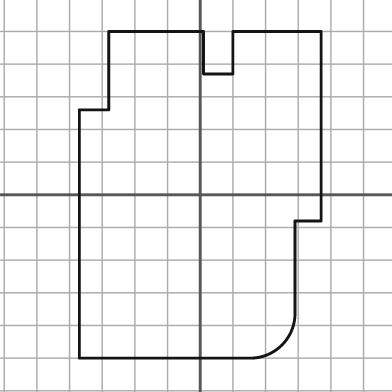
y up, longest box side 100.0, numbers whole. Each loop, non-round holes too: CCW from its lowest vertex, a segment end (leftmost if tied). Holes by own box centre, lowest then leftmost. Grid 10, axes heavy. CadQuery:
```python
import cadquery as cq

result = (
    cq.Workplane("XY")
    .moveTo(-37.0, -50.0)
    .lineTo(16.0, -50.0)
    .threePointArc((25.0, -46.0), (29.0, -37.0))
    .lineTo(29.0, -8.0)
    .lineTo(37.0, -8.0)
    .lineTo(37.0, 50.0)
    .lineTo(10.0, 50.0)
    .lineTo(10.0, 37.0)
    .lineTo(1.0, 37.0)
    .lineTo(1.0, 50.0)
    .lineTo(-28.0, 50.0)
    .lineTo(-28.0, 26.0)
    .lineTo(-37.0, 26.0)
    .close()
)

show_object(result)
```